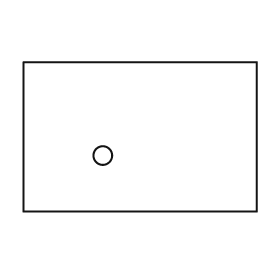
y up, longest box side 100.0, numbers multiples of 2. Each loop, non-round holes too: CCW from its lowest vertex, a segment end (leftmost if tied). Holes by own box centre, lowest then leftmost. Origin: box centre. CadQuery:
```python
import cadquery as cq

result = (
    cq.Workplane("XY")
    .moveTo(-50.0, -32.0)
    .lineTo(50.0, -32.0)
    .lineTo(50.0, 32.0)
    .lineTo(-50.0, 32.0)
    .close()
    .moveTo(-16.0, -8.0)
    .circle(4.0)
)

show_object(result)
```